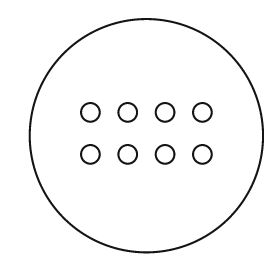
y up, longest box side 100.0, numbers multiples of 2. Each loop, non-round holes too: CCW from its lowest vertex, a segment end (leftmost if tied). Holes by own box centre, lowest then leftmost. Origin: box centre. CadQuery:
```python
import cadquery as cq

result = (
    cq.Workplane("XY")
    .moveTo(0.0, 0.0)
    .circle(50.0)
    .moveTo(-24.0, -8.0)
    .circle(4.0)
    .moveTo(-8.0, -8.0)
    .circle(4.0)
    .moveTo(8.0, -8.0)
    .circle(4.0)
    .moveTo(24.0, -8.0)
    .circle(4.0)
    .moveTo(-24.0, 10.0)
    .circle(4.0)
    .moveTo(-8.0, 10.0)
    .circle(4.0)
    .moveTo(8.0, 10.0)
    .circle(4.0)
    .moveTo(24.0, 10.0)
    .circle(4.0)
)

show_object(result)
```